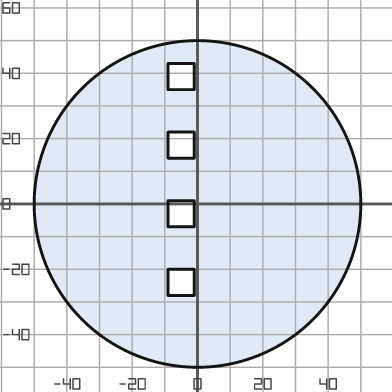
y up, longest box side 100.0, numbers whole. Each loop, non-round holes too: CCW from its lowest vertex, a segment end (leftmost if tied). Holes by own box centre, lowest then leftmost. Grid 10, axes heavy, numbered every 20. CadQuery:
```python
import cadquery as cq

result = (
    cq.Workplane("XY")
    .moveTo(0.0, 0.0)
    .circle(50.0)
    .moveTo(-9.0, -28.0)
    .lineTo(-1.0, -28.0)
    .lineTo(-1.0, -20.0)
    .lineTo(-9.0, -20.0)
    .close()
    .moveTo(-9.0, -7.0)
    .lineTo(-1.0, -7.0)
    .lineTo(-1.0, 1.0)
    .lineTo(-9.0, 1.0)
    .close()
    .moveTo(-9.0, 14.0)
    .lineTo(-1.0, 14.0)
    .lineTo(-1.0, 22.0)
    .lineTo(-9.0, 22.0)
    .close()
    .moveTo(-9.0, 35.0)
    .lineTo(-1.0, 35.0)
    .lineTo(-1.0, 43.0)
    .lineTo(-9.0, 43.0)
    .close()
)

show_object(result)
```